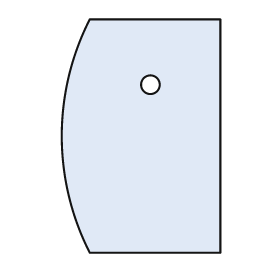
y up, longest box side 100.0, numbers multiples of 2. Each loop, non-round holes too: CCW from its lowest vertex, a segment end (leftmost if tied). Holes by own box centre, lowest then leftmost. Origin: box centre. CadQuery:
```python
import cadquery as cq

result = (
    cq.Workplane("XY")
    .moveTo(-22.0, -50.0)
    .lineTo(34.0, -50.0)
    .lineTo(34.0, 50.0)
    .lineTo(-22.0, 50.0)
    .threePointArc((-34.0, 0.0), (-22.0, -50.0))
    .close()
    .moveTo(4.0, 22.0)
    .circle(4.0)
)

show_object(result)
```